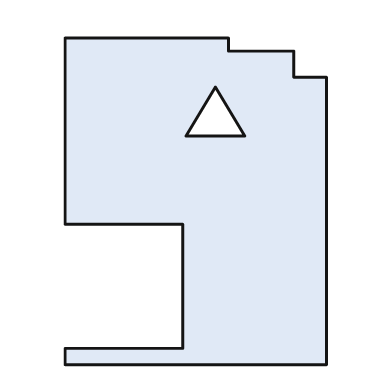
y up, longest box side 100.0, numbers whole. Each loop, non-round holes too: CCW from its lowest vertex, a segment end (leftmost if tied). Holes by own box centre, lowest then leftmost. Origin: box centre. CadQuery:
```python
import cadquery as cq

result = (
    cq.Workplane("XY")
    .moveTo(-40.0, -50.0)
    .lineTo(40.0, -50.0)
    .lineTo(40.0, 38.0)
    .lineTo(30.0, 38.0)
    .lineTo(30.0, 46.0)
    .lineTo(10.0, 46.0)
    .lineTo(10.0, 50.0)
    .lineTo(-40.0, 50.0)
    .lineTo(-40.0, -7.0)
    .lineTo(-4.0, -7.0)
    .lineTo(-4.0, -45.0)
    .lineTo(-40.0, -45.0)
    .close()
    .moveTo(-3.0, 20.0)
    .lineTo(15.0, 20.0)
    .lineTo(6.0, 35.0)
    .close()
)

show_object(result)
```